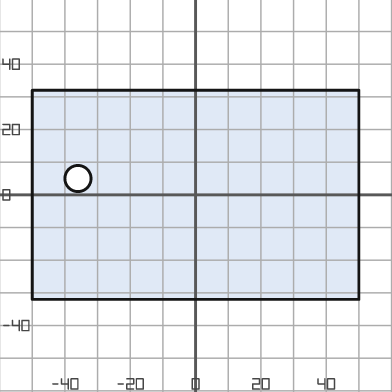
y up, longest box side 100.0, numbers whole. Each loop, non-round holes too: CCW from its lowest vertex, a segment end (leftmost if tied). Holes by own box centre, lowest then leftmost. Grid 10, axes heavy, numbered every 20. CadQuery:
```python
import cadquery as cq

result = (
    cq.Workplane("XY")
    .moveTo(-50.0, -32.0)
    .lineTo(50.0, -32.0)
    .lineTo(50.0, 32.0)
    .lineTo(-50.0, 32.0)
    .close()
    .moveTo(-36.0, 5.0)
    .circle(4.0)
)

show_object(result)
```